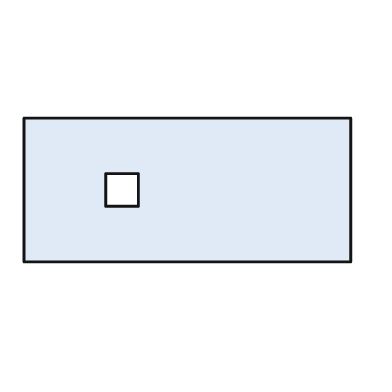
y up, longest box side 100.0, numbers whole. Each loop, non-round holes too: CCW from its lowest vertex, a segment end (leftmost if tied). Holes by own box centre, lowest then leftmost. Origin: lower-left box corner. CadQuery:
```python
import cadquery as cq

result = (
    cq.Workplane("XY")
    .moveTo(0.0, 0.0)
    .lineTo(100.0, 0.0)
    .lineTo(100.0, 44.0)
    .lineTo(0.0, 44.0)
    .close()
    .moveTo(25.0, 17.0)
    .lineTo(35.0, 17.0)
    .lineTo(35.0, 27.0)
    .lineTo(25.0, 27.0)
    .close()
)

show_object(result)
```